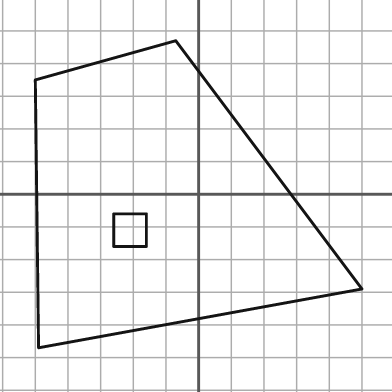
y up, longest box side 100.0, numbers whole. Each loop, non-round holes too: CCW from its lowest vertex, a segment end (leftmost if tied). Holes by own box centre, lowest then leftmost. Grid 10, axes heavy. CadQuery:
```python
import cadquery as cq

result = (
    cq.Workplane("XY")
    .moveTo(-49.0, -47.0)
    .lineTo(50.0, -29.0)
    .lineTo(-7.0, 47.0)
    .lineTo(-50.0, 35.0)
    .close()
    .moveTo(-26.0, -16.0)
    .lineTo(-16.0, -16.0)
    .lineTo(-16.0, -6.0)
    .lineTo(-26.0, -6.0)
    .close()
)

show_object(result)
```